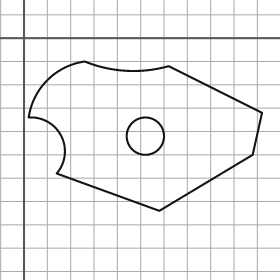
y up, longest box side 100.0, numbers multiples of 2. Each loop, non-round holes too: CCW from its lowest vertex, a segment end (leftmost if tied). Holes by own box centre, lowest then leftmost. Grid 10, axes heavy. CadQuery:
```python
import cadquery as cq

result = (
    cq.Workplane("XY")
    .moveTo(58.0, -74.0)
    .lineTo(98.0, -50.0)
    .lineTo(102.0, -32.0)
    .lineTo(62.0, -12.0)
    .threePointArc((44.0, -14.0), (26.0, -10.0))
    .threePointArc((10.0, -18.0), (2.0, -34.0))
    .threePointArc((16.0, -42.0), (14.0, -58.0))
    .close()
    .moveTo(52.0, -42.0)
    .circle(8.0)
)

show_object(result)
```